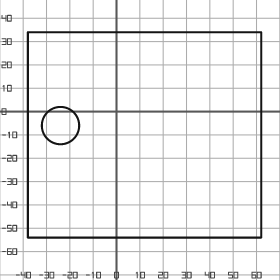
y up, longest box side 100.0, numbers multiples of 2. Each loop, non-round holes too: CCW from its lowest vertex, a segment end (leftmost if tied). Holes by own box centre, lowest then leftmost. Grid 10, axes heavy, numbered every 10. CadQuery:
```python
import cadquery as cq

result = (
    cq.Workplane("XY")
    .moveTo(-38.0, -54.0)
    .lineTo(62.0, -54.0)
    .lineTo(62.0, 34.0)
    .lineTo(-38.0, 34.0)
    .close()
    .moveTo(-24.0, -6.0)
    .circle(8.0)
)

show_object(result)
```